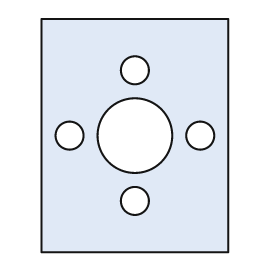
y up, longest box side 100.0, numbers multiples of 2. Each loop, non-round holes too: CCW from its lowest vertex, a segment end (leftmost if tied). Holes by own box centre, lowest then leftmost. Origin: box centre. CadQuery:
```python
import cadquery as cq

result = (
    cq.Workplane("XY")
    .moveTo(-40.0, -50.0)
    .lineTo(40.0, -50.0)
    .lineTo(40.0, 50.0)
    .lineTo(-40.0, 50.0)
    .close()
    .moveTo(0.0, -28.0)
    .circle(6.0)
    .moveTo(-28.0, 0.0)
    .circle(6.0)
    .moveTo(0.0, 0.0)
    .circle(16.0)
    .moveTo(28.0, 0.0)
    .circle(6.0)
    .moveTo(0.0, 28.0)
    .circle(6.0)
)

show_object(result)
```